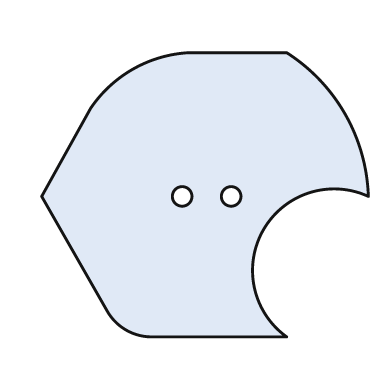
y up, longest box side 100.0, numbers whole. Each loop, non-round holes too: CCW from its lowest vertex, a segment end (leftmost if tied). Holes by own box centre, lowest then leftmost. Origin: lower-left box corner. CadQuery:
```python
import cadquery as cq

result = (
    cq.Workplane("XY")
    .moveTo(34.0, 0.0)
    .lineTo(75.0, 0.0)
    .threePointArc((68.0, 33.0), (100.0, 43.0))
    .threePointArc((93.0, 68.0), (75.0, 87.0))
    .lineTo(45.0, 87.0)
    .threePointArc((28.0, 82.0), (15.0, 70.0))
    .lineTo(0.0, 43.0)
    .lineTo(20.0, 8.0)
    .threePointArc((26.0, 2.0), (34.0, 0.0))
    .close()
    .moveTo(43.0, 43.0)
    .circle(3.0)
    .moveTo(58.0, 43.0)
    .circle(3.0)
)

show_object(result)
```